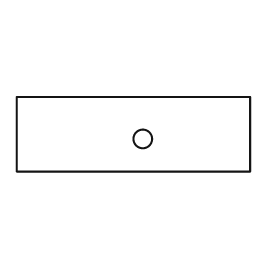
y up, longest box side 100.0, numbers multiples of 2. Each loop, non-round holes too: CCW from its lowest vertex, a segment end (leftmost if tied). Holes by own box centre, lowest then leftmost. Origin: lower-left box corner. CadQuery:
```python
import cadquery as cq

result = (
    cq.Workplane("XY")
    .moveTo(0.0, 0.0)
    .lineTo(100.0, 0.0)
    .lineTo(100.0, 32.0)
    .lineTo(0.0, 32.0)
    .close()
    .moveTo(54.0, 14.0)
    .circle(4.0)
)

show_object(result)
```